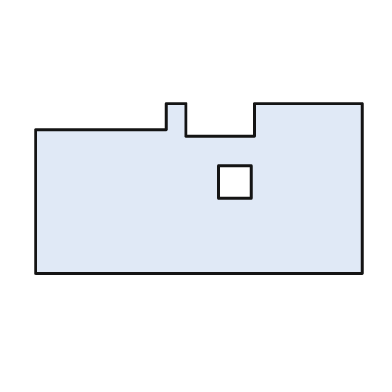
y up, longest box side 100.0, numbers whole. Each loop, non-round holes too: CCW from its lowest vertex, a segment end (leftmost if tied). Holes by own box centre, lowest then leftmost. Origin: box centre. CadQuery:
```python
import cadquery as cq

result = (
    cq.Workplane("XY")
    .moveTo(-50.0, -26.0)
    .lineTo(50.0, -26.0)
    .lineTo(50.0, 26.0)
    .lineTo(17.0, 26.0)
    .lineTo(17.0, 16.0)
    .lineTo(-4.0, 16.0)
    .lineTo(-4.0, 26.0)
    .lineTo(-10.0, 26.0)
    .lineTo(-10.0, 18.0)
    .lineTo(-50.0, 18.0)
    .close()
    .moveTo(6.0, -3.0)
    .lineTo(16.0, -3.0)
    .lineTo(16.0, 7.0)
    .lineTo(6.0, 7.0)
    .close()
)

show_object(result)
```